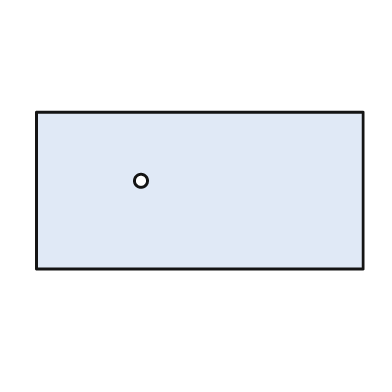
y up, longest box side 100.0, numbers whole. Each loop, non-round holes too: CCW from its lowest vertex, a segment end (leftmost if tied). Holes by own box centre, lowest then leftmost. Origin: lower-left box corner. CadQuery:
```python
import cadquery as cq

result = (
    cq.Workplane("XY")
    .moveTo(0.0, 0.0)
    .lineTo(100.0, 0.0)
    .lineTo(100.0, 48.0)
    .lineTo(0.0, 48.0)
    .close()
    .moveTo(32.0, 27.0)
    .circle(2.0)
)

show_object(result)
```